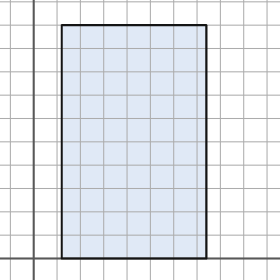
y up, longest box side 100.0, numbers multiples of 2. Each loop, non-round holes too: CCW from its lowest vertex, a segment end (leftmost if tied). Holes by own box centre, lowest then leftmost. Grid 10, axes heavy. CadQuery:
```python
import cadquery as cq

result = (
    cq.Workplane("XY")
    .moveTo(12.0, 0.0)
    .lineTo(74.0, 0.0)
    .lineTo(74.0, 100.0)
    .lineTo(12.0, 100.0)
    .close()
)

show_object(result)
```